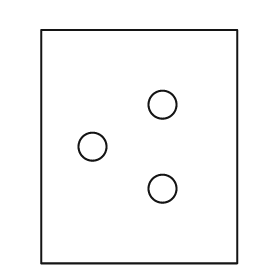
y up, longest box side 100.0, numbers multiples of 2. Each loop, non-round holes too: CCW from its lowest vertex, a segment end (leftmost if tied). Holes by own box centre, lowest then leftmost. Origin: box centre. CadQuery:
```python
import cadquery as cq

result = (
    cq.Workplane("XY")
    .moveTo(-42.0, -50.0)
    .lineTo(42.0, -50.0)
    .lineTo(42.0, 50.0)
    .lineTo(-42.0, 50.0)
    .close()
    .moveTo(10.0, -18.0)
    .circle(6.0)
    .moveTo(-20.0, 0.0)
    .circle(6.0)
    .moveTo(10.0, 18.0)
    .circle(6.0)
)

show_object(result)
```